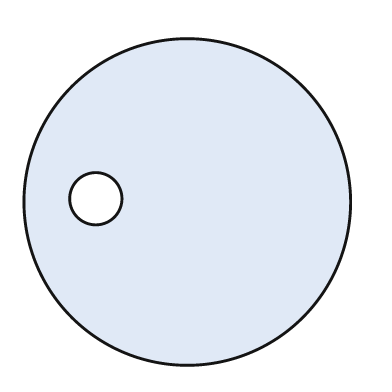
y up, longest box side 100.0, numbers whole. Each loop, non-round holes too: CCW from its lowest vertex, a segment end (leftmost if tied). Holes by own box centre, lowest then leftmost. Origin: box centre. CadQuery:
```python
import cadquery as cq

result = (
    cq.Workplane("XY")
    .moveTo(0.0, 0.0)
    .circle(50.0)
    .moveTo(-28.0, 1.0)
    .circle(8.0)
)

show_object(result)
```